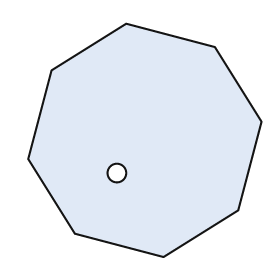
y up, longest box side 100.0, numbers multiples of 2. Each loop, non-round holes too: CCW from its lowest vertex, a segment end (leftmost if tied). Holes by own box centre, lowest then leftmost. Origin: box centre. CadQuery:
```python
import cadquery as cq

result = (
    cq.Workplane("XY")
    .moveTo(8.0, -50.0)
    .lineTo(40.0, -30.0)
    .lineTo(50.0, 8.0)
    .lineTo(30.0, 40.0)
    .lineTo(-8.0, 50.0)
    .lineTo(-40.0, 30.0)
    .lineTo(-50.0, -8.0)
    .lineTo(-30.0, -40.0)
    .close()
    .moveTo(-12.0, -14.0)
    .circle(4.0)
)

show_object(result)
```